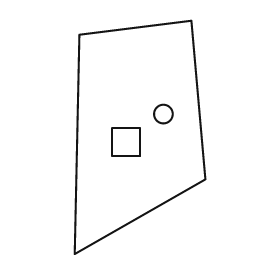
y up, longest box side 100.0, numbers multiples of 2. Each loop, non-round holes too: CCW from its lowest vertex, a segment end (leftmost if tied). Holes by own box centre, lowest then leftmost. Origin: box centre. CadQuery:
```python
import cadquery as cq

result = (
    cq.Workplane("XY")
    .moveTo(-28.0, -50.0)
    .lineTo(28.0, -18.0)
    .lineTo(22.0, 50.0)
    .lineTo(-26.0, 44.0)
    .close()
    .moveTo(-12.0, -8.0)
    .lineTo(0.0, -8.0)
    .lineTo(0.0, 4.0)
    .lineTo(-12.0, 4.0)
    .close()
    .moveTo(10.0, 10.0)
    .circle(4.0)
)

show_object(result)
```